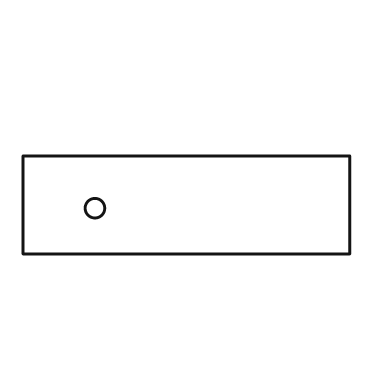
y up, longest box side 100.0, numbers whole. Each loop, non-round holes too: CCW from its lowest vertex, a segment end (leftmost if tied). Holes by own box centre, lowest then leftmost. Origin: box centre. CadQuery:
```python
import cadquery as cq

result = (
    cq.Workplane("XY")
    .moveTo(-50.0, -15.0)
    .lineTo(50.0, -15.0)
    .lineTo(50.0, 15.0)
    .lineTo(-50.0, 15.0)
    .close()
    .moveTo(-28.0, -1.0)
    .circle(3.0)
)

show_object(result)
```